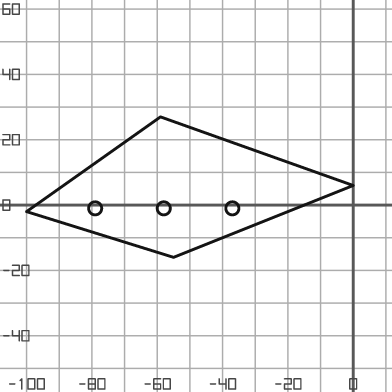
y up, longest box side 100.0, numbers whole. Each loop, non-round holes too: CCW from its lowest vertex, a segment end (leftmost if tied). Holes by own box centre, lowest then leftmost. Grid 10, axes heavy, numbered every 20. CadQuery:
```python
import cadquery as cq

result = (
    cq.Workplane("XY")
    .moveTo(-55.0, -16.0)
    .lineTo(0.0, 6.0)
    .lineTo(-59.0, 27.0)
    .lineTo(-100.0, -2.0)
    .close()
    .moveTo(-79.0, -1.0)
    .circle(2.0)
    .moveTo(-58.0, -1.0)
    .circle(2.0)
    .moveTo(-37.0, -1.0)
    .circle(2.0)
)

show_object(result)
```